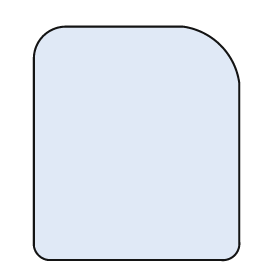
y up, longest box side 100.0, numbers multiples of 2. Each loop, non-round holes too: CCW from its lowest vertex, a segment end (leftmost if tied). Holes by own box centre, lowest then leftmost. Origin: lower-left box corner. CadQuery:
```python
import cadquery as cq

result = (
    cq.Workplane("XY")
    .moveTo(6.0, 0.0)
    .lineTo(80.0, 0.0)
    .threePointArc((86.0, 2.0), (88.0, 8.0))
    .lineTo(88.0, 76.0)
    .threePointArc((80.0, 92.0), (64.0, 100.0))
    .lineTo(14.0, 100.0)
    .threePointArc((4.0, 96.0), (0.0, 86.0))
    .lineTo(0.0, 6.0)
    .threePointArc((2.0, 2.0), (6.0, 0.0))
    .close()
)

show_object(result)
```